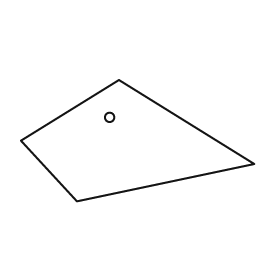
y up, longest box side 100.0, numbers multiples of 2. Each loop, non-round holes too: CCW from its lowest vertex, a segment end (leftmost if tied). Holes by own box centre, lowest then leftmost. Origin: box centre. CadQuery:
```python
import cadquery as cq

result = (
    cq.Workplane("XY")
    .moveTo(-26.0, -26.0)
    .lineTo(50.0, -10.0)
    .lineTo(-8.0, 26.0)
    .lineTo(-50.0, 0.0)
    .close()
    .moveTo(-12.0, 10.0)
    .circle(2.0)
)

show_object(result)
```